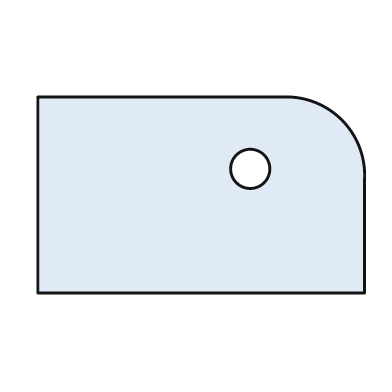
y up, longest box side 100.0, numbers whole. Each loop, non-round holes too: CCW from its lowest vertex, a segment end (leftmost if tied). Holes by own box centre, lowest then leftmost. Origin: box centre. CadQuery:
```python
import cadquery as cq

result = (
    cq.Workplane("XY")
    .moveTo(-50.0, -30.0)
    .lineTo(50.0, -30.0)
    .lineTo(50.0, 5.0)
    .threePointArc((43.0, 23.0), (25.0, 30.0))
    .lineTo(-50.0, 30.0)
    .close()
    .moveTo(15.0, 8.0)
    .circle(6.0)
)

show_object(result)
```